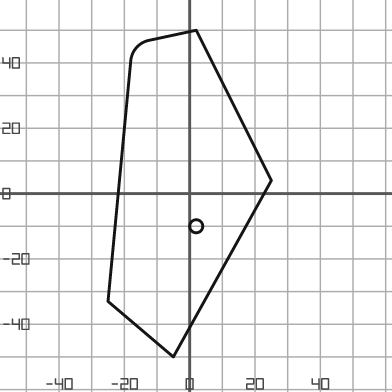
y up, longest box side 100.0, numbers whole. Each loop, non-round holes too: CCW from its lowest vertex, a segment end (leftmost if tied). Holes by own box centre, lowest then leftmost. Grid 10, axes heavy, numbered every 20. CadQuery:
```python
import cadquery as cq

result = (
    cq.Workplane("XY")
    .moveTo(-5.0, -50.0)
    .lineTo(25.0, 4.0)
    .lineTo(2.0, 50.0)
    .lineTo(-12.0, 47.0)
    .threePointArc((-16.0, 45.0), (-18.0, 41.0))
    .lineTo(-25.0, -33.0)
    .close()
    .moveTo(2.0, -10.0)
    .circle(2.0)
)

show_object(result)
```